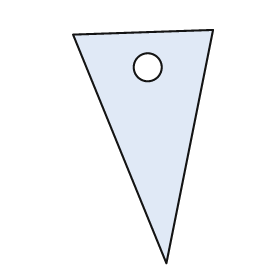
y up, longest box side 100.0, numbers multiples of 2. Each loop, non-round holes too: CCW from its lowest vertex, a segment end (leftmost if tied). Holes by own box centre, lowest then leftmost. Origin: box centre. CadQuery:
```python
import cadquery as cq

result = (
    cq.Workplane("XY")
    .moveTo(10.0, -50.0)
    .lineTo(30.0, 50.0)
    .lineTo(-30.0, 48.0)
    .close()
    .moveTo(2.0, 34.0)
    .circle(6.0)
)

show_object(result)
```